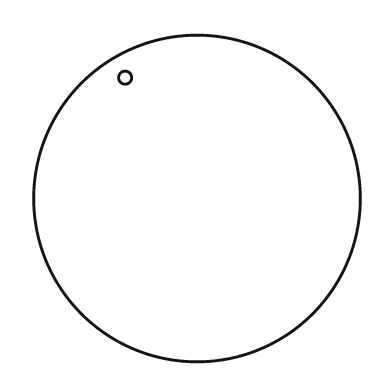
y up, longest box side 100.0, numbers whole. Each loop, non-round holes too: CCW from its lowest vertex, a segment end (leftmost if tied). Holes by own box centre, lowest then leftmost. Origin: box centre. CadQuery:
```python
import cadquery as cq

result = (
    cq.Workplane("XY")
    .moveTo(0.0, 0.0)
    .circle(50.0)
    .moveTo(-22.0, 37.0)
    .circle(2.0)
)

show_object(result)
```